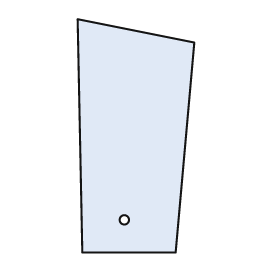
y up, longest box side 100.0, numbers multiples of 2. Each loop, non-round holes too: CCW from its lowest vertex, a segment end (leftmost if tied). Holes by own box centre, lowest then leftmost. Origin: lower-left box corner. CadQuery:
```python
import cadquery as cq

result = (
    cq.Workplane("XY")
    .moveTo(2.0, 0.0)
    .lineTo(42.0, 0.0)
    .lineTo(50.0, 90.0)
    .lineTo(0.0, 100.0)
    .close()
    .moveTo(20.0, 14.0)
    .circle(2.0)
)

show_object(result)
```